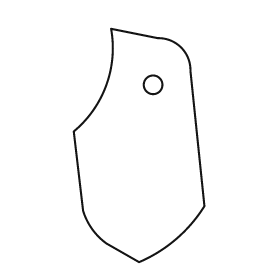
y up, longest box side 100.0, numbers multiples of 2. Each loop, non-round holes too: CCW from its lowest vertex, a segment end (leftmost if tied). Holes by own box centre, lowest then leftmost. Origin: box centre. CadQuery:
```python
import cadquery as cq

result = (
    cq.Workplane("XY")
    .moveTo(0.0, -50.0)
    .threePointArc((16.0, -40.0), (28.0, -26.0))
    .lineTo(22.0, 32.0)
    .threePointArc((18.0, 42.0), (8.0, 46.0))
    .lineTo(-12.0, 50.0)
    .threePointArc((-14.0, 26.0), (-28.0, 6.0))
    .lineTo(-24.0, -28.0)
    .threePointArc((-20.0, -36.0), (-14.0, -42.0))
    .close()
    .moveTo(6.0, 26.0)
    .circle(4.0)
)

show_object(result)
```